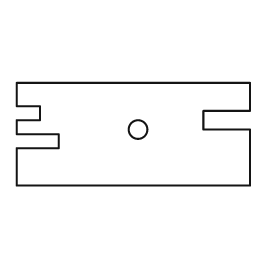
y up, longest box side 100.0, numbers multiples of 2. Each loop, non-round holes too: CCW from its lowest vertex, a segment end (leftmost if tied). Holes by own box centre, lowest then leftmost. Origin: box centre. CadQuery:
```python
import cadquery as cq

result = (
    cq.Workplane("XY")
    .moveTo(-50.0, -22.0)
    .lineTo(50.0, -22.0)
    .lineTo(50.0, 2.0)
    .lineTo(30.0, 2.0)
    .lineTo(30.0, 10.0)
    .lineTo(50.0, 10.0)
    .lineTo(50.0, 22.0)
    .lineTo(-50.0, 22.0)
    .lineTo(-50.0, 12.0)
    .lineTo(-40.0, 12.0)
    .lineTo(-40.0, 6.0)
    .lineTo(-50.0, 6.0)
    .lineTo(-50.0, 0.0)
    .lineTo(-32.0, 0.0)
    .lineTo(-32.0, -6.0)
    .lineTo(-50.0, -6.0)
    .close()
    .moveTo(2.0, 2.0)
    .circle(4.0)
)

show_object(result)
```